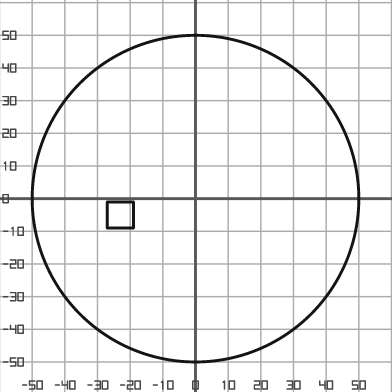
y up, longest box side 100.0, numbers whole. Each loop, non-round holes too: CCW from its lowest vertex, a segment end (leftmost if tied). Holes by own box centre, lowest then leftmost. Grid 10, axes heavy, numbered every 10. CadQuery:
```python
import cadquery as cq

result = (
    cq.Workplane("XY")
    .moveTo(0.0, 0.0)
    .circle(50.0)
    .moveTo(-27.0, -9.0)
    .lineTo(-19.0, -9.0)
    .lineTo(-19.0, -1.0)
    .lineTo(-27.0, -1.0)
    .close()
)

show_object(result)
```